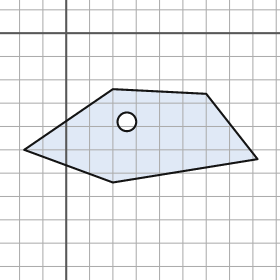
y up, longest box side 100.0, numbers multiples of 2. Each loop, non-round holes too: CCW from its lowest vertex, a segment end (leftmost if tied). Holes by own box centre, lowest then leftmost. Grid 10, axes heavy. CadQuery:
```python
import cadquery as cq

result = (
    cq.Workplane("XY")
    .moveTo(20.0, -64.0)
    .lineTo(82.0, -54.0)
    .lineTo(60.0, -26.0)
    .lineTo(20.0, -24.0)
    .lineTo(-18.0, -50.0)
    .close()
    .moveTo(26.0, -38.0)
    .circle(4.0)
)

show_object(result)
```